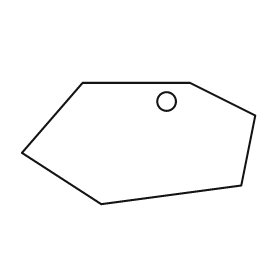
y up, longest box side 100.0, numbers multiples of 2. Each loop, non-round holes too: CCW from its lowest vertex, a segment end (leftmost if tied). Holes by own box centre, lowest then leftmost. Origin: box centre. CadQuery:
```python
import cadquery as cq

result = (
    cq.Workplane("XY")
    .moveTo(-16.0, -26.0)
    .lineTo(44.0, -18.0)
    .lineTo(50.0, 12.0)
    .lineTo(22.0, 26.0)
    .lineTo(-24.0, 26.0)
    .lineTo(-50.0, -4.0)
    .close()
    .moveTo(12.0, 18.0)
    .circle(4.0)
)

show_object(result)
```